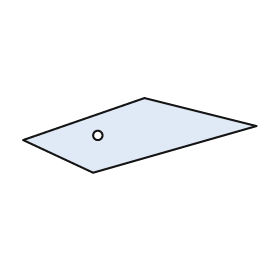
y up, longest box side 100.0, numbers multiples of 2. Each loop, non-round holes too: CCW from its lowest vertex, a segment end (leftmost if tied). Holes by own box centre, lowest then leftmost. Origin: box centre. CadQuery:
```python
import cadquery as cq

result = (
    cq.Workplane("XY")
    .moveTo(-20.0, -16.0)
    .lineTo(50.0, 4.0)
    .lineTo(2.0, 16.0)
    .lineTo(-50.0, -2.0)
    .close()
    .moveTo(-18.0, 0.0)
    .circle(2.0)
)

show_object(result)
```